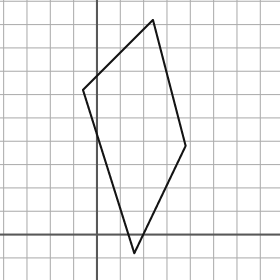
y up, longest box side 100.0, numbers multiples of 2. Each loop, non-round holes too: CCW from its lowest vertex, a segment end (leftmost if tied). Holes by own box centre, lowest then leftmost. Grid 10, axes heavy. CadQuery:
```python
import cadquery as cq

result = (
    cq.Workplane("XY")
    .moveTo(16.0, -8.0)
    .lineTo(38.0, 38.0)
    .lineTo(24.0, 92.0)
    .lineTo(-6.0, 62.0)
    .close()
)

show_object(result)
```